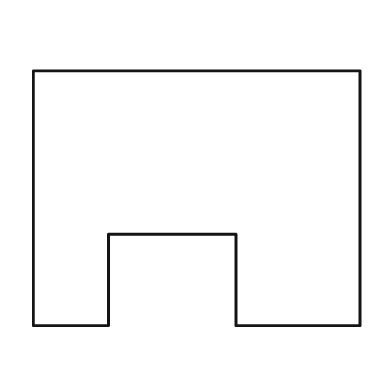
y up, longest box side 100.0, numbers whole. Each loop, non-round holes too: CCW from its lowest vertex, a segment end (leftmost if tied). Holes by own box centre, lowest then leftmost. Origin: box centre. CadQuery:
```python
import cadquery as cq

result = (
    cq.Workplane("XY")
    .moveTo(-50.0, -39.0)
    .lineTo(-27.0, -39.0)
    .lineTo(-27.0, -11.0)
    .lineTo(12.0, -11.0)
    .lineTo(12.0, -39.0)
    .lineTo(50.0, -39.0)
    .lineTo(50.0, 39.0)
    .lineTo(-50.0, 39.0)
    .close()
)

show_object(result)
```